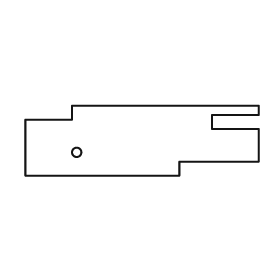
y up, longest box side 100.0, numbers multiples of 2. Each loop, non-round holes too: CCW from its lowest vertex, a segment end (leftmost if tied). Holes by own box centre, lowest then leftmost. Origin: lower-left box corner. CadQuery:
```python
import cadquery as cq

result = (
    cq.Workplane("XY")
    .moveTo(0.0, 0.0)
    .lineTo(66.0, 0.0)
    .lineTo(66.0, 6.0)
    .lineTo(100.0, 6.0)
    .lineTo(100.0, 20.0)
    .lineTo(80.0, 20.0)
    .lineTo(80.0, 26.0)
    .lineTo(100.0, 26.0)
    .lineTo(100.0, 30.0)
    .lineTo(20.0, 30.0)
    .lineTo(20.0, 24.0)
    .lineTo(0.0, 24.0)
    .close()
    .moveTo(22.0, 10.0)
    .circle(2.0)
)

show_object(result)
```